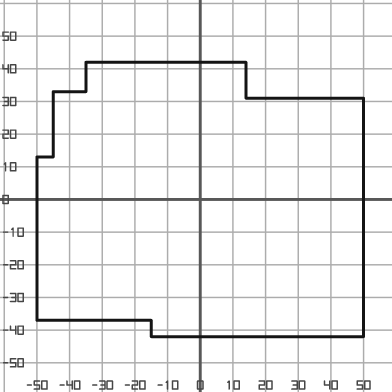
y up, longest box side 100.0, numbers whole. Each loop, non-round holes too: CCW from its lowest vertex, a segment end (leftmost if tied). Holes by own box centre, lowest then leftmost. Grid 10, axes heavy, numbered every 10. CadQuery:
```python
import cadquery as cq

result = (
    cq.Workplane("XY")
    .moveTo(-15.0, -42.0)
    .lineTo(50.0, -42.0)
    .lineTo(50.0, 31.0)
    .lineTo(14.0, 31.0)
    .lineTo(14.0, 42.0)
    .lineTo(-35.0, 42.0)
    .lineTo(-35.0, 33.0)
    .lineTo(-45.0, 33.0)
    .lineTo(-45.0, 13.0)
    .lineTo(-50.0, 13.0)
    .lineTo(-50.0, -37.0)
    .lineTo(-15.0, -37.0)
    .close()
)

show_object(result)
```